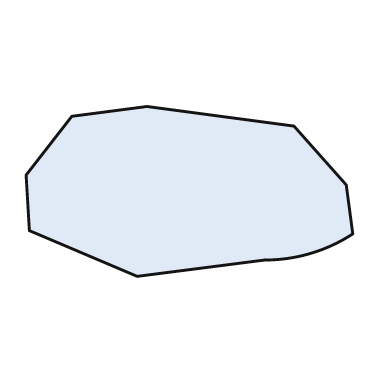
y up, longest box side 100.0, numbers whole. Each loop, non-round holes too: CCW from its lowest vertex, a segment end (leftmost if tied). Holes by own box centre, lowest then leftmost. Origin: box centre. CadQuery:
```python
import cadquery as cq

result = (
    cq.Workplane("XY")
    .moveTo(-16.0, -26.0)
    .lineTo(23.0, -21.0)
    .threePointArc((37.0, -19.0), (50.0, -13.0))
    .lineTo(48.0, 2.0)
    .lineTo(32.0, 20.0)
    .lineTo(-13.0, 26.0)
    .lineTo(-36.0, 23.0)
    .lineTo(-50.0, 5.0)
    .lineTo(-49.0, -12.0)
    .close()
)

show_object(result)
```